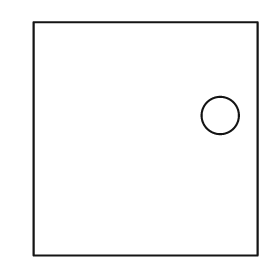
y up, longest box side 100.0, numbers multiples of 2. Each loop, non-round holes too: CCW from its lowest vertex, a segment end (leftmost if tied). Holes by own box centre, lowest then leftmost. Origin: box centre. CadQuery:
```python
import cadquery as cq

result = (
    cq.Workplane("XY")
    .moveTo(-48.0, -50.0)
    .lineTo(48.0, -50.0)
    .lineTo(48.0, 50.0)
    .lineTo(-48.0, 50.0)
    .close()
    .moveTo(32.0, 10.0)
    .circle(8.0)
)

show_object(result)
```